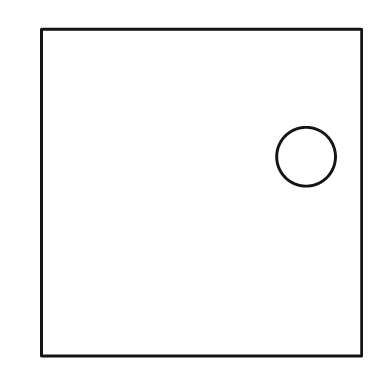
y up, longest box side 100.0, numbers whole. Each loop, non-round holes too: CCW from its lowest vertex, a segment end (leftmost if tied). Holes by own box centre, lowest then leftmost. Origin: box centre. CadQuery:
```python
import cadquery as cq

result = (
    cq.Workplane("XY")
    .moveTo(-49.0, -50.0)
    .lineTo(49.0, -50.0)
    .lineTo(49.0, 50.0)
    .lineTo(-49.0, 50.0)
    .close()
    .moveTo(32.0, 11.0)
    .circle(9.0)
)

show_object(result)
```